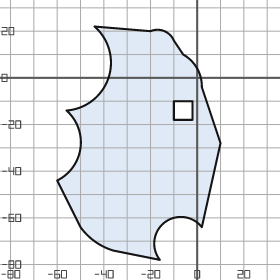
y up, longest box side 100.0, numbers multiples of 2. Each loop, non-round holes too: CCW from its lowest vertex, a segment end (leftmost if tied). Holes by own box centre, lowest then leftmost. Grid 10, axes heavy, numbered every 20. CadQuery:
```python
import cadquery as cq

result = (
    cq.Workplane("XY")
    .moveTo(-16.0, -78.0)
    .threePointArc((-14.0, -62.0), (2.0, -64.0))
    .lineTo(10.0, -28.0)
    .lineTo(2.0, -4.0)
    .threePointArc((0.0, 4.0), (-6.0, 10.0))
    .lineTo(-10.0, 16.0)
    .threePointArc((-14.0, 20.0), (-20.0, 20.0))
    .lineTo(-44.0, 22.0)
    .threePointArc((-38.0, 0.0), (-56.0, -14.0))
    .threePointArc((-50.0, -30.0), (-60.0, -44.0))
    .lineTo(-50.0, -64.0)
    .threePointArc((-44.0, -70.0), (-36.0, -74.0))
    .close()
    .moveTo(-10.0, -18.0)
    .lineTo(-2.0, -18.0)
    .lineTo(-2.0, -10.0)
    .lineTo(-10.0, -10.0)
    .close()
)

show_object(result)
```